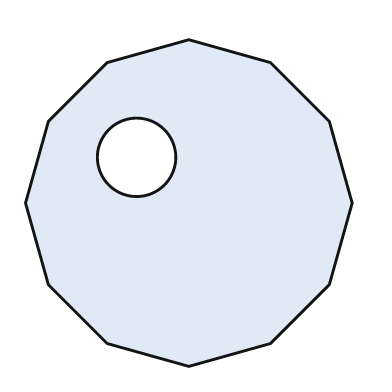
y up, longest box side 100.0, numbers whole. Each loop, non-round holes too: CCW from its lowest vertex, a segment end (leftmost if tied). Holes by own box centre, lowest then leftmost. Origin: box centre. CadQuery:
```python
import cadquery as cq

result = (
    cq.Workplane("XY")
    .moveTo(0.0, -50.0)
    .lineTo(25.0, -43.0)
    .lineTo(43.0, -25.0)
    .lineTo(50.0, 0.0)
    .lineTo(43.0, 25.0)
    .lineTo(25.0, 43.0)
    .lineTo(0.0, 50.0)
    .lineTo(-25.0, 43.0)
    .lineTo(-43.0, 25.0)
    .lineTo(-50.0, 0.0)
    .lineTo(-43.0, -25.0)
    .lineTo(-25.0, -43.0)
    .close()
    .moveTo(-16.0, 14.0)
    .circle(12.0)
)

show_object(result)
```